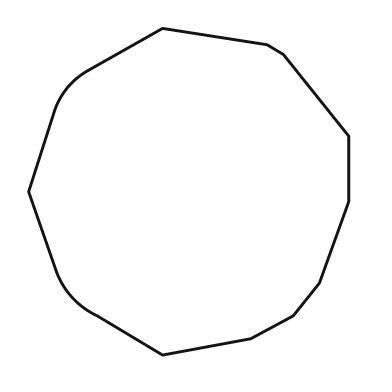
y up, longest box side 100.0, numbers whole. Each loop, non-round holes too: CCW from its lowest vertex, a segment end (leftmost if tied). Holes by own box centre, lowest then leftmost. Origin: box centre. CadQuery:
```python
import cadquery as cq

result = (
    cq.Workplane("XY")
    .moveTo(-8.0, -50.0)
    .lineTo(19.0, -45.0)
    .lineTo(32.0, -38.0)
    .lineTo(40.0, -28.0)
    .lineTo(49.0, -3.0)
    .lineTo(49.0, 17.0)
    .lineTo(29.0, 42.0)
    .lineTo(24.0, 45.0)
    .lineTo(-8.0, 50.0)
    .lineTo(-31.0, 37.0)
    .threePointArc((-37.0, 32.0), (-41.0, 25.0))
    .lineTo(-49.0, 0.0)
    .lineTo(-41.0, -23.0)
    .threePointArc((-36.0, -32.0), (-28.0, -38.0))
    .close()
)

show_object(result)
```